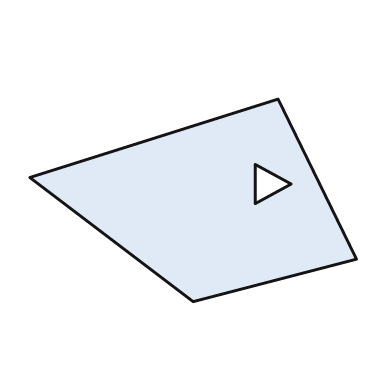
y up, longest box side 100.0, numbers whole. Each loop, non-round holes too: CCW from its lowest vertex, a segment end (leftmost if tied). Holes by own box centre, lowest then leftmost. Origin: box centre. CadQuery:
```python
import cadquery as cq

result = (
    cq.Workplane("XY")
    .moveTo(0.0, -31.0)
    .lineTo(50.0, -18.0)
    .lineTo(26.0, 31.0)
    .lineTo(-50.0, 7.0)
    .close()
    .moveTo(19.0, -1.0)
    .lineTo(30.0, 5.0)
    .lineTo(19.0, 11.0)
    .close()
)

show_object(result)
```